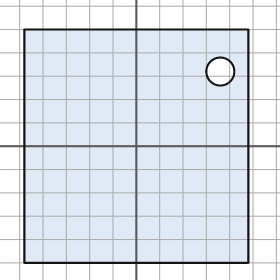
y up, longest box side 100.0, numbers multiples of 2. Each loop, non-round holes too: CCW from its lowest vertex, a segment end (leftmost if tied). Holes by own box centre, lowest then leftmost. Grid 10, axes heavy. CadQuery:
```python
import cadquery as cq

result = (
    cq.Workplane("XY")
    .moveTo(-48.0, -50.0)
    .lineTo(48.0, -50.0)
    .lineTo(48.0, 50.0)
    .lineTo(-48.0, 50.0)
    .close()
    .moveTo(36.0, 32.0)
    .circle(6.0)
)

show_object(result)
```